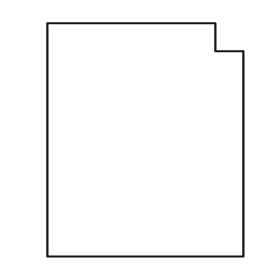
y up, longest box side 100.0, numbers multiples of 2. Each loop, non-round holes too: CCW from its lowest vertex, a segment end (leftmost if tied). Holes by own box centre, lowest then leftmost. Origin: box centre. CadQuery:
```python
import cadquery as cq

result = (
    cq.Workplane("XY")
    .moveTo(-42.0, -50.0)
    .lineTo(42.0, -50.0)
    .lineTo(42.0, 38.0)
    .lineTo(30.0, 38.0)
    .lineTo(30.0, 50.0)
    .lineTo(-42.0, 50.0)
    .close()
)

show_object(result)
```